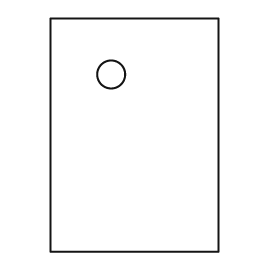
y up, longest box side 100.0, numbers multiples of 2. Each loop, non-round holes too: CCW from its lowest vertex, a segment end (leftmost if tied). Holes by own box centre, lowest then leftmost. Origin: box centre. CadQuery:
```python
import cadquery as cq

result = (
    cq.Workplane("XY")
    .moveTo(-36.0, -50.0)
    .lineTo(36.0, -50.0)
    .lineTo(36.0, 50.0)
    .lineTo(-36.0, 50.0)
    .close()
    .moveTo(-10.0, 26.0)
    .circle(6.0)
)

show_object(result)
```